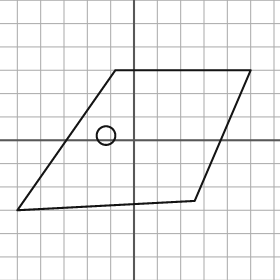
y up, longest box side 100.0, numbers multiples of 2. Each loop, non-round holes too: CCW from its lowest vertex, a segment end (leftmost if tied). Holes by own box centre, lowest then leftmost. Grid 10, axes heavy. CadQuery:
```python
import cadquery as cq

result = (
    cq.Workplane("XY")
    .moveTo(-50.0, -30.0)
    .lineTo(26.0, -26.0)
    .lineTo(50.0, 30.0)
    .lineTo(-8.0, 30.0)
    .close()
    .moveTo(-12.0, 2.0)
    .circle(4.0)
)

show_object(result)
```